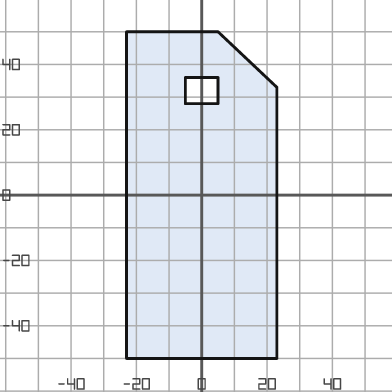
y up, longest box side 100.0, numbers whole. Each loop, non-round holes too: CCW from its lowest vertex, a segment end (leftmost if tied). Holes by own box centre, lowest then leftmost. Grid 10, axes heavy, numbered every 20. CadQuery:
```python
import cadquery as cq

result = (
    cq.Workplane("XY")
    .moveTo(-23.0, -50.0)
    .lineTo(23.0, -50.0)
    .lineTo(23.0, 33.0)
    .lineTo(5.0, 50.0)
    .lineTo(-23.0, 50.0)
    .close()
    .moveTo(-5.0, 28.0)
    .lineTo(5.0, 28.0)
    .lineTo(5.0, 36.0)
    .lineTo(-5.0, 36.0)
    .close()
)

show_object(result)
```